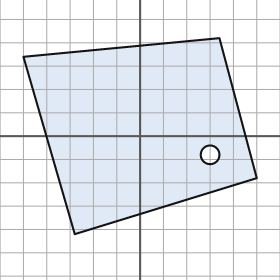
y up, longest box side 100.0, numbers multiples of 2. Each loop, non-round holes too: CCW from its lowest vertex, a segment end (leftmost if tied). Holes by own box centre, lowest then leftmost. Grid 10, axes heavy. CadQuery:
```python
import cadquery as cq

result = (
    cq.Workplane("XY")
    .moveTo(-28.0, -42.0)
    .lineTo(50.0, -18.0)
    .lineTo(34.0, 42.0)
    .lineTo(-50.0, 34.0)
    .close()
    .moveTo(30.0, -8.0)
    .circle(4.0)
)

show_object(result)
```